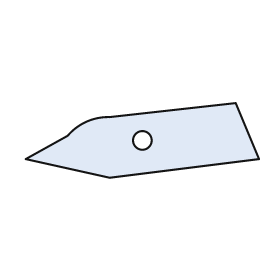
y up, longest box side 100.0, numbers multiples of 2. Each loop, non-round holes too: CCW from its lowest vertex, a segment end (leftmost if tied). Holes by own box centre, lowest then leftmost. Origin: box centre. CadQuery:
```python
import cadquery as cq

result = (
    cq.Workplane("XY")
    .moveTo(-14.0, -16.0)
    .lineTo(50.0, -8.0)
    .lineTo(40.0, 16.0)
    .lineTo(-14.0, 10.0)
    .threePointArc((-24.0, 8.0), (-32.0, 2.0))
    .lineTo(-50.0, -8.0)
    .close()
    .moveTo(0.0, 0.0)
    .circle(4.0)
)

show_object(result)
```